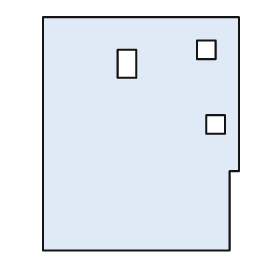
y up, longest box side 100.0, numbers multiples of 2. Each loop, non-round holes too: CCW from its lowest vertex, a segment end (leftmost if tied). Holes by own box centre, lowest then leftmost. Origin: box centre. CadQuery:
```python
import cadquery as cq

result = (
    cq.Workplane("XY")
    .moveTo(-42.0, -50.0)
    .lineTo(38.0, -50.0)
    .lineTo(38.0, -16.0)
    .lineTo(42.0, -16.0)
    .lineTo(42.0, 50.0)
    .lineTo(-42.0, 50.0)
    .close()
    .moveTo(28.0, 0.0)
    .lineTo(36.0, 0.0)
    .lineTo(36.0, 8.0)
    .lineTo(28.0, 8.0)
    .close()
    .moveTo(-10.0, 24.0)
    .lineTo(-2.0, 24.0)
    .lineTo(-2.0, 36.0)
    .lineTo(-10.0, 36.0)
    .close()
    .moveTo(24.0, 32.0)
    .lineTo(32.0, 32.0)
    .lineTo(32.0, 40.0)
    .lineTo(24.0, 40.0)
    .close()
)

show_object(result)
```